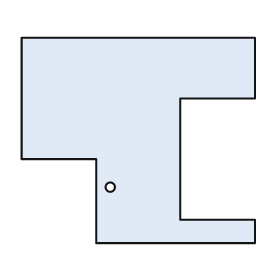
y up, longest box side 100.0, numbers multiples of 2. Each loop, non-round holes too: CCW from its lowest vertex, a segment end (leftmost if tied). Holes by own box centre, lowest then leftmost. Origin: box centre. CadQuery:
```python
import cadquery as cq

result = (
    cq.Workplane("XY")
    .moveTo(-18.0, -44.0)
    .lineTo(50.0, -44.0)
    .lineTo(50.0, -34.0)
    .lineTo(18.0, -34.0)
    .lineTo(18.0, 18.0)
    .lineTo(50.0, 18.0)
    .lineTo(50.0, 44.0)
    .lineTo(-50.0, 44.0)
    .lineTo(-50.0, -8.0)
    .lineTo(-18.0, -8.0)
    .close()
    .moveTo(-12.0, -20.0)
    .circle(2.0)
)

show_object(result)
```